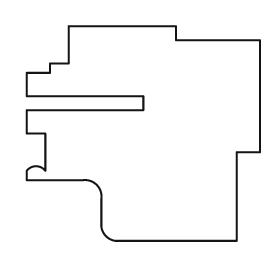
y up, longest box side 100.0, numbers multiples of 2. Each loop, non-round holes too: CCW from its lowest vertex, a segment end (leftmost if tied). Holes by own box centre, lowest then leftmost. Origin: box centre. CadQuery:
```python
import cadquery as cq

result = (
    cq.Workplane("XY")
    .moveTo(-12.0, -46.0)
    .lineTo(40.0, -46.0)
    .lineTo(40.0, -8.0)
    .lineTo(50.0, -8.0)
    .lineTo(50.0, 40.0)
    .lineTo(14.0, 40.0)
    .lineTo(14.0, 46.0)
    .lineTo(-32.0, 46.0)
    .lineTo(-32.0, 30.0)
    .lineTo(-40.0, 30.0)
    .lineTo(-40.0, 26.0)
    .lineTo(-50.0, 26.0)
    .lineTo(-50.0, 16.0)
    .lineTo(0.0, 16.0)
    .lineTo(0.0, 10.0)
    .lineTo(-50.0, 10.0)
    .lineTo(-50.0, 0.0)
    .lineTo(-42.0, 0.0)
    .lineTo(-42.0, -16.0)
    .threePointArc((-46.0, -14.0), (-50.0, -16.0))
    .lineTo(-50.0, -20.0)
    .lineTo(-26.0, -20.0)
    .threePointArc((-20.0, -22.0), (-18.0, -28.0))
    .lineTo(-18.0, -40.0)
    .threePointArc((-16.0, -44.0), (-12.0, -46.0))
    .close()
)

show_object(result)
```